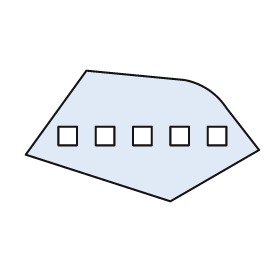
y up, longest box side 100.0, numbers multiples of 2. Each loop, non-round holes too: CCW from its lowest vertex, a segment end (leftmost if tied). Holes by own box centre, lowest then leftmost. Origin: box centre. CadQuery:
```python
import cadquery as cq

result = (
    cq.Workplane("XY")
    .moveTo(12.0, -28.0)
    .lineTo(50.0, -6.0)
    .lineTo(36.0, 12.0)
    .threePointArc((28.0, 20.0), (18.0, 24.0))
    .lineTo(-24.0, 28.0)
    .lineTo(-50.0, -8.0)
    .close()
    .moveTo(-36.0, -4.0)
    .lineTo(-28.0, -4.0)
    .lineTo(-28.0, 4.0)
    .lineTo(-36.0, 4.0)
    .close()
    .moveTo(-20.0, -4.0)
    .lineTo(-12.0, -4.0)
    .lineTo(-12.0, 4.0)
    .lineTo(-20.0, 4.0)
    .close()
    .moveTo(-4.0, -4.0)
    .lineTo(4.0, -4.0)
    .lineTo(4.0, 4.0)
    .lineTo(-4.0, 4.0)
    .close()
    .moveTo(12.0, -4.0)
    .lineTo(20.0, -4.0)
    .lineTo(20.0, 4.0)
    .lineTo(12.0, 4.0)
    .close()
    .moveTo(28.0, -4.0)
    .lineTo(36.0, -4.0)
    .lineTo(36.0, 4.0)
    .lineTo(28.0, 4.0)
    .close()
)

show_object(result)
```